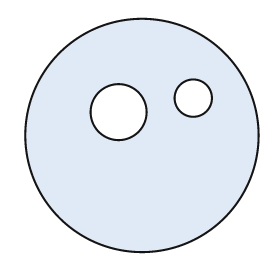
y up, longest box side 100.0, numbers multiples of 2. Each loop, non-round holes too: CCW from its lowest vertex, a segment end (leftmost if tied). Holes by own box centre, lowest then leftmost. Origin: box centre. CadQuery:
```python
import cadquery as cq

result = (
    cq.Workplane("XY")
    .moveTo(0.0, 0.0)
    .circle(50.0)
    .moveTo(-10.0, 10.0)
    .circle(12.0)
    .moveTo(22.0, 16.0)
    .circle(8.0)
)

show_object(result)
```